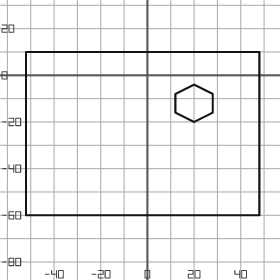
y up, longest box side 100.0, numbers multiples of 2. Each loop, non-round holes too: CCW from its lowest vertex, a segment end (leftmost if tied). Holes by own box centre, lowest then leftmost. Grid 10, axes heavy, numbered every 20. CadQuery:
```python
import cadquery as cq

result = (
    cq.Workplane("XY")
    .moveTo(-52.0, -60.0)
    .lineTo(48.0, -60.0)
    .lineTo(48.0, 10.0)
    .lineTo(-52.0, 10.0)
    .close()
    .moveTo(20.0, -20.0)
    .lineTo(28.0, -16.0)
    .lineTo(28.0, -8.0)
    .lineTo(20.0, -4.0)
    .lineTo(12.0, -8.0)
    .lineTo(12.0, -16.0)
    .close()
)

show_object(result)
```